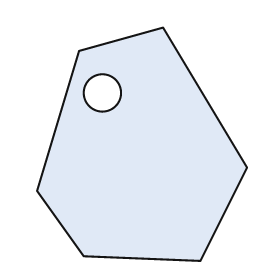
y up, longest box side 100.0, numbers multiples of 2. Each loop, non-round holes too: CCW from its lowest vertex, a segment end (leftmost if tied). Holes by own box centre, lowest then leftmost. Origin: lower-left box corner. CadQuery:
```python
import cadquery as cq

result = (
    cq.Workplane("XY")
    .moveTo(70.0, 0.0)
    .lineTo(90.0, 40.0)
    .lineTo(54.0, 100.0)
    .lineTo(18.0, 90.0)
    .lineTo(0.0, 30.0)
    .lineTo(20.0, 2.0)
    .close()
    .moveTo(28.0, 72.0)
    .circle(8.0)
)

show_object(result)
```